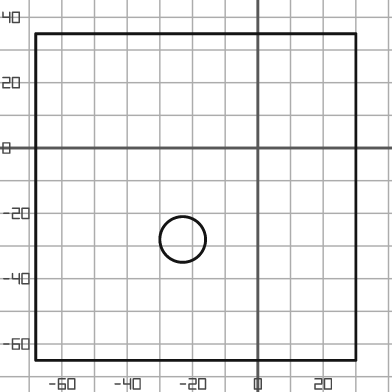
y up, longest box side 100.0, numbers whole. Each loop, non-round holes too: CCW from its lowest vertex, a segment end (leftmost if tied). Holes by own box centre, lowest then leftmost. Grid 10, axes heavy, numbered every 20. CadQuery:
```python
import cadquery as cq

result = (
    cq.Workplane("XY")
    .moveTo(-68.0, -65.0)
    .lineTo(30.0, -65.0)
    .lineTo(30.0, 35.0)
    .lineTo(-68.0, 35.0)
    .close()
    .moveTo(-23.0, -28.0)
    .circle(7.0)
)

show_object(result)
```